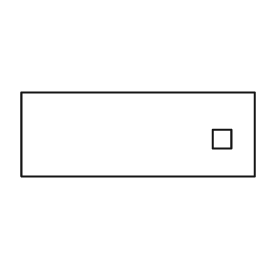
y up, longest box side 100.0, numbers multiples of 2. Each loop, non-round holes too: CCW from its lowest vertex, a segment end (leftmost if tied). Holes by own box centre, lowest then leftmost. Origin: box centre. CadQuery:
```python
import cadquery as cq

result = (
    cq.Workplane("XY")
    .moveTo(-50.0, -18.0)
    .lineTo(50.0, -18.0)
    .lineTo(50.0, 18.0)
    .lineTo(-50.0, 18.0)
    .close()
    .moveTo(32.0, -6.0)
    .lineTo(40.0, -6.0)
    .lineTo(40.0, 2.0)
    .lineTo(32.0, 2.0)
    .close()
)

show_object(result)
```